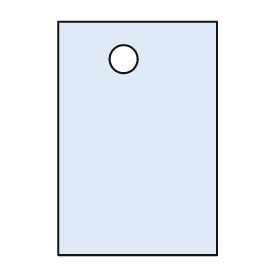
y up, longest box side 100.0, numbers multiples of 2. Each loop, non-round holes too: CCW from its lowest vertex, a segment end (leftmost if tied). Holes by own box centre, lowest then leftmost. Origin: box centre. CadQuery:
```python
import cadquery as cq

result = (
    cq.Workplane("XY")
    .moveTo(-34.0, -50.0)
    .lineTo(34.0, -50.0)
    .lineTo(34.0, 50.0)
    .lineTo(-34.0, 50.0)
    .close()
    .moveTo(-6.0, 34.0)
    .circle(6.0)
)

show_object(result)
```